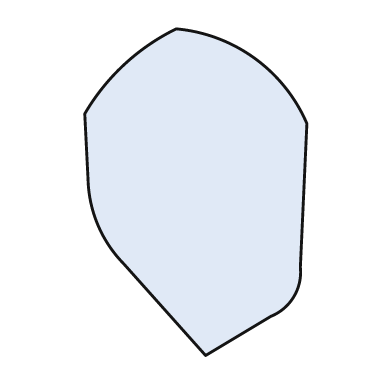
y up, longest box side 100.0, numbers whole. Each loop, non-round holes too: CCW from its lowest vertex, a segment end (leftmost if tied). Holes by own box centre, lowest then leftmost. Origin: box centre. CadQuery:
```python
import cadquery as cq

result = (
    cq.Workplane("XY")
    .moveTo(3.0, -50.0)
    .lineTo(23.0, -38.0)
    .threePointArc((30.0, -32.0), (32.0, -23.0))
    .lineTo(34.0, 21.0)
    .threePointArc((18.0, 41.0), (-6.0, 50.0))
    .threePointArc((-22.0, 39.0), (-34.0, 24.0))
    .lineTo(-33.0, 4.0)
    .threePointArc((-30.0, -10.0), (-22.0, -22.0))
    .close()
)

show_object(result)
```